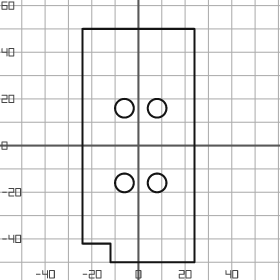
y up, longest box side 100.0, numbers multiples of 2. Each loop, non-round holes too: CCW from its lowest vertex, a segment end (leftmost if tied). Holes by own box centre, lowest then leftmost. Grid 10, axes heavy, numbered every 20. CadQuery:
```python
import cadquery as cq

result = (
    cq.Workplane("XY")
    .moveTo(-12.0, -50.0)
    .lineTo(24.0, -50.0)
    .lineTo(24.0, 50.0)
    .lineTo(-24.0, 50.0)
    .lineTo(-24.0, -42.0)
    .lineTo(-12.0, -42.0)
    .close()
    .moveTo(-6.0, -16.0)
    .circle(4.0)
    .moveTo(8.0, -16.0)
    .circle(4.0)
    .moveTo(-6.0, 16.0)
    .circle(4.0)
    .moveTo(8.0, 16.0)
    .circle(4.0)
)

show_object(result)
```